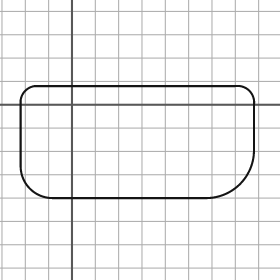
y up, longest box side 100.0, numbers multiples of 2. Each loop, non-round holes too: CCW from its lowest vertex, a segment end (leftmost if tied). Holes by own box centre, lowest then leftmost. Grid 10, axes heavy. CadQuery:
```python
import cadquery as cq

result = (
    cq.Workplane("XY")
    .moveTo(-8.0, -40.0)
    .lineTo(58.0, -40.0)
    .threePointArc((72.0, -34.0), (78.0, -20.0))
    .lineTo(78.0, 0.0)
    .threePointArc((76.0, 6.0), (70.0, 8.0))
    .lineTo(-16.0, 8.0)
    .threePointArc((-20.0, 6.0), (-22.0, 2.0))
    .lineTo(-22.0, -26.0)
    .threePointArc((-18.0, -36.0), (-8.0, -40.0))
    .close()
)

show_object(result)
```